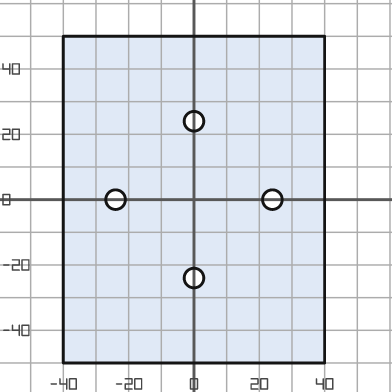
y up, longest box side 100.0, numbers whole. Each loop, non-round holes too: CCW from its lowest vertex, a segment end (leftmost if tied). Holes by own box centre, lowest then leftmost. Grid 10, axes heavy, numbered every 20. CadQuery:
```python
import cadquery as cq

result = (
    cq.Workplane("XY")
    .moveTo(-40.0, -50.0)
    .lineTo(40.0, -50.0)
    .lineTo(40.0, 50.0)
    .lineTo(-40.0, 50.0)
    .close()
    .moveTo(0.0, -24.0)
    .circle(3.0)
    .moveTo(-24.0, 0.0)
    .circle(3.0)
    .moveTo(24.0, 0.0)
    .circle(3.0)
    .moveTo(0.0, 24.0)
    .circle(3.0)
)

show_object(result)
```